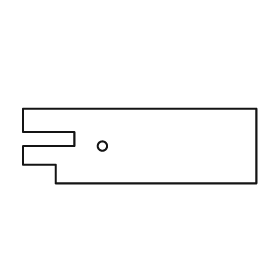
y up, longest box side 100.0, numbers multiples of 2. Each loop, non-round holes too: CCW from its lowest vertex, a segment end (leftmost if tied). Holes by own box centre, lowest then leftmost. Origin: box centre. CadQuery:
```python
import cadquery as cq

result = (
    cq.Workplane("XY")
    .moveTo(-36.0, -16.0)
    .lineTo(50.0, -16.0)
    .lineTo(50.0, 16.0)
    .lineTo(-50.0, 16.0)
    .lineTo(-50.0, 6.0)
    .lineTo(-28.0, 6.0)
    .lineTo(-28.0, 0.0)
    .lineTo(-50.0, 0.0)
    .lineTo(-50.0, -8.0)
    .lineTo(-36.0, -8.0)
    .close()
    .moveTo(-16.0, 0.0)
    .circle(2.0)
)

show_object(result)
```